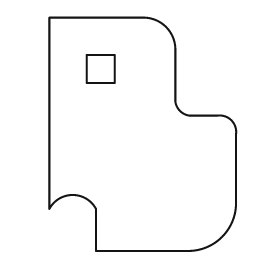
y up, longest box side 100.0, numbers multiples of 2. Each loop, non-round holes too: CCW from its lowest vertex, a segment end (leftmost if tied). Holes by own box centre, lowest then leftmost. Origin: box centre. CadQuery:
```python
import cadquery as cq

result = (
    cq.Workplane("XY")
    .moveTo(-20.0, -50.0)
    .lineTo(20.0, -50.0)
    .threePointArc((34.0, -44.0), (40.0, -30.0))
    .lineTo(40.0, 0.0)
    .threePointArc((38.0, 6.0), (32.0, 8.0))
    .lineTo(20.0, 8.0)
    .threePointArc((16.0, 10.0), (14.0, 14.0))
    .lineTo(14.0, 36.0)
    .threePointArc((10.0, 46.0), (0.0, 50.0))
    .lineTo(-40.0, 50.0)
    .lineTo(-40.0, -32.0)
    .threePointArc((-30.0, -26.0), (-20.0, -32.0))
    .close()
    .moveTo(-24.0, 22.0)
    .lineTo(-12.0, 22.0)
    .lineTo(-12.0, 34.0)
    .lineTo(-24.0, 34.0)
    .close()
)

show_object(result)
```